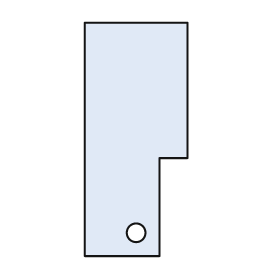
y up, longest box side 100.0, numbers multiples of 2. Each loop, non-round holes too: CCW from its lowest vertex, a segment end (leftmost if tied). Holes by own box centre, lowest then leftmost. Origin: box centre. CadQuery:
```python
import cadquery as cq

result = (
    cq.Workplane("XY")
    .moveTo(-22.0, -50.0)
    .lineTo(10.0, -50.0)
    .lineTo(10.0, -8.0)
    .lineTo(22.0, -8.0)
    .lineTo(22.0, 50.0)
    .lineTo(-22.0, 50.0)
    .close()
    .moveTo(0.0, -40.0)
    .circle(4.0)
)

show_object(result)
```